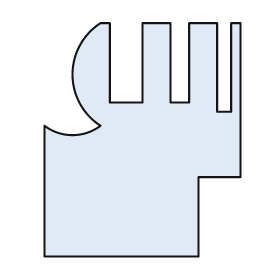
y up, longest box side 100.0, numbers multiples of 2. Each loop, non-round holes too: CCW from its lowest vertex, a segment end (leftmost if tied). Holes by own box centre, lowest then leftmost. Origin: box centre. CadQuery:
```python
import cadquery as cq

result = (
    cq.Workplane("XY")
    .moveTo(-42.0, -50.0)
    .lineTo(24.0, -50.0)
    .lineTo(24.0, -16.0)
    .lineTo(42.0, -16.0)
    .lineTo(42.0, 50.0)
    .lineTo(38.0, 50.0)
    .lineTo(38.0, 12.0)
    .lineTo(32.0, 12.0)
    .lineTo(32.0, 50.0)
    .lineTo(20.0, 50.0)
    .lineTo(20.0, 16.0)
    .lineTo(12.0, 16.0)
    .lineTo(12.0, 50.0)
    .lineTo(0.0, 50.0)
    .lineTo(0.0, 16.0)
    .lineTo(-14.0, 16.0)
    .lineTo(-14.0, 50.0)
    .lineTo(-18.0, 50.0)
    .threePointArc((-30.0, 28.0), (-18.0, 6.0))
    .threePointArc((-30.0, 2.0), (-42.0, 6.0))
    .close()
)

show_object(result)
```